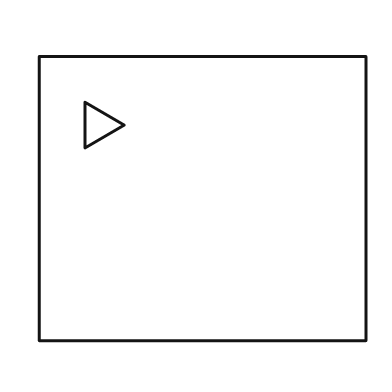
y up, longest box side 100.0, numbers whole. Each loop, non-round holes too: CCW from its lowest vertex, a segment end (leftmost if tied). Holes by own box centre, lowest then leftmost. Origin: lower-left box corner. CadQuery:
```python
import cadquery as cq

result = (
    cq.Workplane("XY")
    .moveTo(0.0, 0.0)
    .lineTo(100.0, 0.0)
    .lineTo(100.0, 87.0)
    .lineTo(0.0, 87.0)
    .close()
    .moveTo(14.0, 59.0)
    .lineTo(26.0, 66.0)
    .lineTo(14.0, 73.0)
    .close()
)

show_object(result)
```